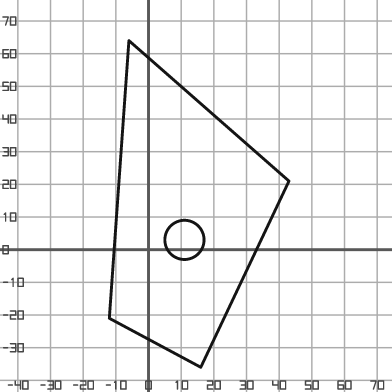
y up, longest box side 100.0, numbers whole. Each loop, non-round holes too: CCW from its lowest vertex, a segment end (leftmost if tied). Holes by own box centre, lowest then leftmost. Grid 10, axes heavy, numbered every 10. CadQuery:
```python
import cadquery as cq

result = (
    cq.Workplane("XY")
    .moveTo(16.0, -36.0)
    .lineTo(43.0, 21.0)
    .lineTo(-6.0, 64.0)
    .lineTo(-12.0, -21.0)
    .close()
    .moveTo(11.0, 3.0)
    .circle(6.0)
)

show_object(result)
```